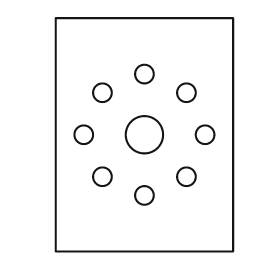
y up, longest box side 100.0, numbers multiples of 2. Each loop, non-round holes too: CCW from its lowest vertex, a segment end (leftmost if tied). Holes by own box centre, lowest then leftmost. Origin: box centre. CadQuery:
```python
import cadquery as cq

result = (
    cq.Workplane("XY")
    .moveTo(-38.0, -50.0)
    .lineTo(38.0, -50.0)
    .lineTo(38.0, 50.0)
    .lineTo(-38.0, 50.0)
    .close()
    .moveTo(0.0, -26.0)
    .circle(4.0)
    .moveTo(-18.0, -18.0)
    .circle(4.0)
    .moveTo(18.0, -18.0)
    .circle(4.0)
    .moveTo(-26.0, 0.0)
    .circle(4.0)
    .moveTo(0.0, 0.0)
    .circle(8.0)
    .moveTo(26.0, 0.0)
    .circle(4.0)
    .moveTo(-18.0, 18.0)
    .circle(4.0)
    .moveTo(18.0, 18.0)
    .circle(4.0)
    .moveTo(0.0, 26.0)
    .circle(4.0)
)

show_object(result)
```